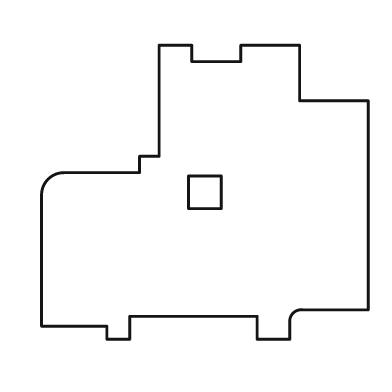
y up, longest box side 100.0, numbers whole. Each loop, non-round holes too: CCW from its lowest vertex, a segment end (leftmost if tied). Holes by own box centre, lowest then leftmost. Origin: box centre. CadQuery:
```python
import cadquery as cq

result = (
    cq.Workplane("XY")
    .moveTo(-30.0, -45.0)
    .lineTo(-23.0, -45.0)
    .lineTo(-23.0, -38.0)
    .lineTo(16.0, -38.0)
    .lineTo(16.0, -45.0)
    .lineTo(26.0, -45.0)
    .lineTo(26.0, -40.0)
    .threePointArc((27.0, -37.0), (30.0, -36.0))
    .lineTo(50.0, -36.0)
    .lineTo(50.0, 28.0)
    .lineTo(29.0, 28.0)
    .lineTo(29.0, 45.0)
    .lineTo(11.0, 45.0)
    .lineTo(11.0, 40.0)
    .lineTo(-4.0, 40.0)
    .lineTo(-4.0, 45.0)
    .lineTo(-14.0, 45.0)
    .lineTo(-14.0, 11.0)
    .lineTo(-20.0, 11.0)
    .lineTo(-20.0, 6.0)
    .lineTo(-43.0, 6.0)
    .threePointArc((-48.0, 4.0), (-50.0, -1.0))
    .lineTo(-50.0, -41.0)
    .lineTo(-30.0, -41.0)
    .close()
    .moveTo(-5.0, -5.0)
    .lineTo(5.0, -5.0)
    .lineTo(5.0, 5.0)
    .lineTo(-5.0, 5.0)
    .close()
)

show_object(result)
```